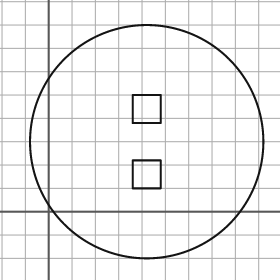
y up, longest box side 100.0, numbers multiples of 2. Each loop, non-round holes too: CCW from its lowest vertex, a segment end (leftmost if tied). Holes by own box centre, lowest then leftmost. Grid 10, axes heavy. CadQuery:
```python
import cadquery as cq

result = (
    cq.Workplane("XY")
    .moveTo(42.0, 30.0)
    .circle(50.0)
    .moveTo(36.0, 10.0)
    .lineTo(48.0, 10.0)
    .lineTo(48.0, 22.0)
    .lineTo(36.0, 22.0)
    .close()
    .moveTo(36.0, 38.0)
    .lineTo(48.0, 38.0)
    .lineTo(48.0, 50.0)
    .lineTo(36.0, 50.0)
    .close()
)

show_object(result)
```